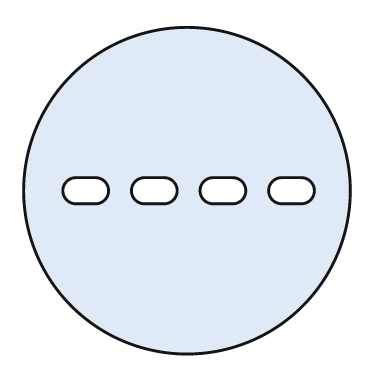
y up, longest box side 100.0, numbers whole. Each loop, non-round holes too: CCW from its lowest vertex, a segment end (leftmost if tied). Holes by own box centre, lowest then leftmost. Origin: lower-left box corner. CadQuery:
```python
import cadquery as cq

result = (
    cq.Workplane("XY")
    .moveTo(50.0, 50.0)
    .circle(50.0)
    .moveTo(16.0, 46.0)
    .lineTo(22.0, 46.0)
    .threePointArc((26.0, 50.0), (22.0, 54.0))
    .lineTo(16.0, 54.0)
    .threePointArc((12.0, 50.0), (16.0, 46.0))
    .close()
    .moveTo(37.0, 46.0)
    .lineTo(43.0, 46.0)
    .threePointArc((47.0, 50.0), (43.0, 54.0))
    .lineTo(37.0, 54.0)
    .threePointArc((33.0, 50.0), (37.0, 46.0))
    .close()
    .moveTo(58.0, 46.0)
    .lineTo(64.0, 46.0)
    .threePointArc((68.0, 50.0), (64.0, 54.0))
    .lineTo(58.0, 54.0)
    .threePointArc((54.0, 50.0), (58.0, 46.0))
    .close()
    .moveTo(79.0, 46.0)
    .lineTo(85.0, 46.0)
    .threePointArc((89.0, 50.0), (85.0, 54.0))
    .lineTo(79.0, 54.0)
    .threePointArc((75.0, 50.0), (79.0, 46.0))
    .close()
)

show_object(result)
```